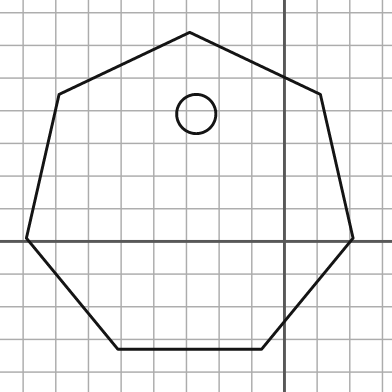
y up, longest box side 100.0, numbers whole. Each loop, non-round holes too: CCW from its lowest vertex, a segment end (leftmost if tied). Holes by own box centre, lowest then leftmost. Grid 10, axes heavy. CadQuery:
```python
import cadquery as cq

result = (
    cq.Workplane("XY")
    .moveTo(-51.0, -33.0)
    .lineTo(-7.0, -33.0)
    .lineTo(21.0, 1.0)
    .lineTo(11.0, 45.0)
    .lineTo(-29.0, 64.0)
    .lineTo(-69.0, 45.0)
    .lineTo(-79.0, 1.0)
    .close()
    .moveTo(-27.0, 39.0)
    .circle(6.0)
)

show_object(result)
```